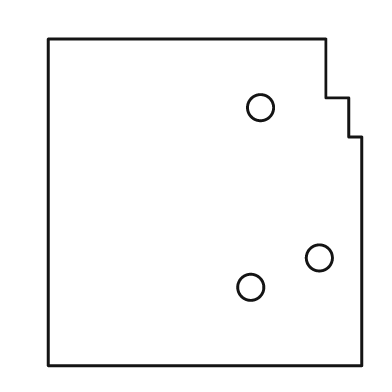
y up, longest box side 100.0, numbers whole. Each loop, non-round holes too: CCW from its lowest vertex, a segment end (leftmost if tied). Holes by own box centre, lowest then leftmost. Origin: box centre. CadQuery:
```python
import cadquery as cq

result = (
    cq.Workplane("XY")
    .moveTo(-48.0, -50.0)
    .lineTo(48.0, -50.0)
    .lineTo(48.0, 20.0)
    .lineTo(44.0, 20.0)
    .lineTo(44.0, 32.0)
    .lineTo(37.0, 32.0)
    .lineTo(37.0, 50.0)
    .lineTo(-48.0, 50.0)
    .close()
    .moveTo(14.0, -26.0)
    .circle(4.0)
    .moveTo(35.0, -17.0)
    .circle(4.0)
    .moveTo(17.0, 29.0)
    .circle(4.0)
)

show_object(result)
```